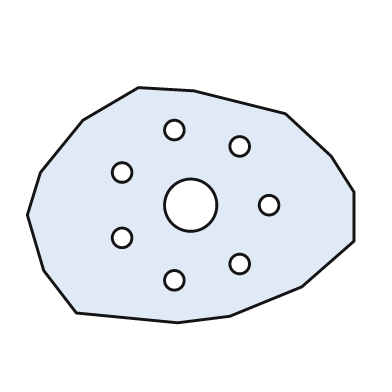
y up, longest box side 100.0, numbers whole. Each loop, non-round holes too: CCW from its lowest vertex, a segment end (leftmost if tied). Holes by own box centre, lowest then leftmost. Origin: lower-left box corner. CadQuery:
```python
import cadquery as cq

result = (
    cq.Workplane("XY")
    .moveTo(46.0, 0.0)
    .lineTo(62.0, 2.0)
    .lineTo(84.0, 11.0)
    .lineTo(100.0, 25.0)
    .lineTo(100.0, 40.0)
    .lineTo(93.0, 51.0)
    .lineTo(79.0, 64.0)
    .lineTo(51.0, 71.0)
    .lineTo(34.0, 72.0)
    .lineTo(17.0, 62.0)
    .lineTo(4.0, 46.0)
    .lineTo(0.0, 33.0)
    .lineTo(5.0, 16.0)
    .lineTo(15.0, 3.0)
    .close()
    .moveTo(45.0, 13.0)
    .circle(3.0)
    .moveTo(65.0, 18.0)
    .circle(3.0)
    .moveTo(29.0, 26.0)
    .circle(3.0)
    .moveTo(50.0, 36.0)
    .circle(8.0)
    .moveTo(74.0, 36.0)
    .circle(3.0)
    .moveTo(29.0, 46.0)
    .circle(3.0)
    .moveTo(65.0, 54.0)
    .circle(3.0)
    .moveTo(45.0, 59.0)
    .circle(3.0)
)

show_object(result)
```